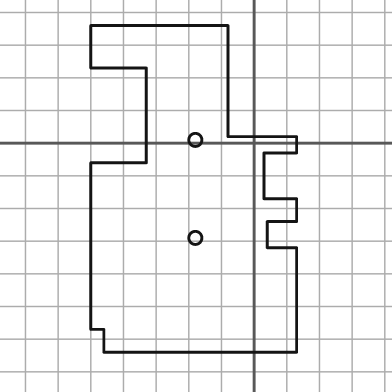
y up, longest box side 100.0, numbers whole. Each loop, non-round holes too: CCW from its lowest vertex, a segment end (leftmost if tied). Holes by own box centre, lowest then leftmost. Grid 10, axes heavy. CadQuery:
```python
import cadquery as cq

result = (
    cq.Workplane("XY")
    .moveTo(-46.0, -64.0)
    .lineTo(13.0, -64.0)
    .lineTo(13.0, -32.0)
    .lineTo(4.0, -32.0)
    .lineTo(4.0, -24.0)
    .lineTo(13.0, -24.0)
    .lineTo(13.0, -17.0)
    .lineTo(3.0, -17.0)
    .lineTo(3.0, -3.0)
    .lineTo(13.0, -3.0)
    .lineTo(13.0, 2.0)
    .lineTo(-8.0, 2.0)
    .lineTo(-8.0, 36.0)
    .lineTo(-50.0, 36.0)
    .lineTo(-50.0, 23.0)
    .lineTo(-33.0, 23.0)
    .lineTo(-33.0, -6.0)
    .lineTo(-50.0, -6.0)
    .lineTo(-50.0, -57.0)
    .lineTo(-46.0, -57.0)
    .close()
    .moveTo(-18.0, -29.0)
    .circle(2.0)
    .moveTo(-18.0, 1.0)
    .circle(2.0)
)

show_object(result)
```